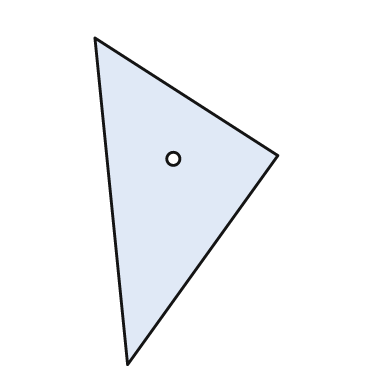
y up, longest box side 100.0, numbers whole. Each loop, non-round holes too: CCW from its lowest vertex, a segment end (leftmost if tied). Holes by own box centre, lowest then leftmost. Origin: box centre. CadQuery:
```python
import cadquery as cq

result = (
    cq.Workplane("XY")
    .moveTo(-18.0, -50.0)
    .lineTo(28.0, 14.0)
    .lineTo(-28.0, 50.0)
    .close()
    .moveTo(-4.0, 13.0)
    .circle(2.0)
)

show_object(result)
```